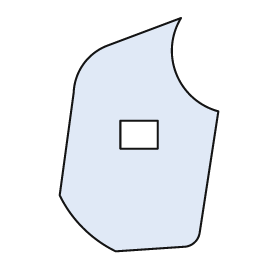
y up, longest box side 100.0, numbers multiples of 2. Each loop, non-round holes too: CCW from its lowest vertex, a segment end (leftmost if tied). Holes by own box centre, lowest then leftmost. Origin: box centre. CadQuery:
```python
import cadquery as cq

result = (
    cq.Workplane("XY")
    .moveTo(-10.0, -50.0)
    .lineTo(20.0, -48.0)
    .threePointArc((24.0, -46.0), (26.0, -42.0))
    .lineTo(34.0, 10.0)
    .threePointArc((16.0, 26.0), (18.0, 50.0))
    .lineTo(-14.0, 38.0)
    .threePointArc((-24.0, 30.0), (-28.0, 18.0))
    .lineTo(-34.0, -26.0)
    .threePointArc((-24.0, -40.0), (-10.0, -50.0))
    .close()
    .moveTo(-8.0, -6.0)
    .lineTo(8.0, -6.0)
    .lineTo(8.0, 6.0)
    .lineTo(-8.0, 6.0)
    .close()
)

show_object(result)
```